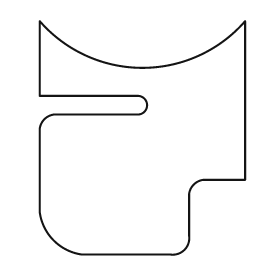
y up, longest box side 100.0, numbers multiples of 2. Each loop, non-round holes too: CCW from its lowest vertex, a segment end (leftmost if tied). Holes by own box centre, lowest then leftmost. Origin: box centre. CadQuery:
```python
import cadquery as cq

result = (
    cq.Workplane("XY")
    .moveTo(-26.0, -50.0)
    .lineTo(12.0, -50.0)
    .threePointArc((18.0, -48.0), (20.0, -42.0))
    .lineTo(20.0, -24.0)
    .threePointArc((22.0, -20.0), (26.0, -18.0))
    .lineTo(44.0, -18.0)
    .lineTo(44.0, 50.0)
    .threePointArc((0.0, 30.0), (-44.0, 50.0))
    .lineTo(-44.0, 18.0)
    .lineTo(-2.0, 18.0)
    .threePointArc((2.0, 14.0), (-2.0, 10.0))
    .lineTo(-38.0, 10.0)
    .threePointArc((-42.0, 8.0), (-44.0, 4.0))
    .lineTo(-44.0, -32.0)
    .threePointArc((-38.0, -44.0), (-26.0, -50.0))
    .close()
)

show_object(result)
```